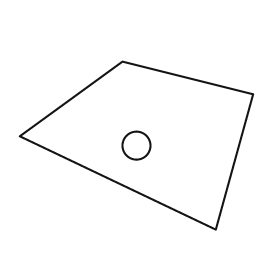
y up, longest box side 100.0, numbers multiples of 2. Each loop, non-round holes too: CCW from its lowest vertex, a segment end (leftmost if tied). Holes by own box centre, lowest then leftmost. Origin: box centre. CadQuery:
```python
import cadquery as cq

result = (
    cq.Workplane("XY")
    .moveTo(34.0, -36.0)
    .lineTo(50.0, 22.0)
    .lineTo(-6.0, 36.0)
    .lineTo(-50.0, 4.0)
    .close()
    .moveTo(0.0, 0.0)
    .circle(6.0)
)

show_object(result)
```